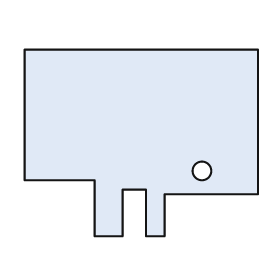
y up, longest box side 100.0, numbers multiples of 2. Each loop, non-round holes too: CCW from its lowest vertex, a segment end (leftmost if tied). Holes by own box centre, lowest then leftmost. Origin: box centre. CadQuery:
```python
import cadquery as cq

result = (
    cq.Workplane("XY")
    .moveTo(-20.0, -40.0)
    .lineTo(-8.0, -40.0)
    .lineTo(-8.0, -20.0)
    .lineTo(2.0, -20.0)
    .lineTo(2.0, -40.0)
    .lineTo(10.0, -40.0)
    .lineTo(10.0, -22.0)
    .lineTo(50.0, -22.0)
    .lineTo(50.0, 40.0)
    .lineTo(-50.0, 40.0)
    .lineTo(-50.0, -16.0)
    .lineTo(-20.0, -16.0)
    .close()
    .moveTo(26.0, -12.0)
    .circle(4.0)
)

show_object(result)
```